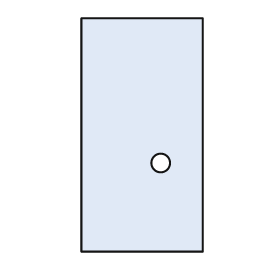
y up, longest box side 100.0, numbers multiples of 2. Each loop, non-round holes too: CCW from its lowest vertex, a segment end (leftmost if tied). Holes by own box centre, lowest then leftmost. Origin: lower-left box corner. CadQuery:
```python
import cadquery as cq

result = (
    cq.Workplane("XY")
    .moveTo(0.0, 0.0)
    .lineTo(52.0, 0.0)
    .lineTo(52.0, 100.0)
    .lineTo(0.0, 100.0)
    .close()
    .moveTo(34.0, 38.0)
    .circle(4.0)
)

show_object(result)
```